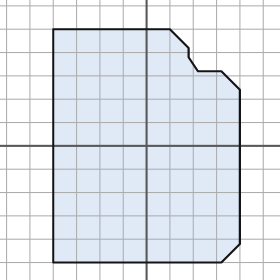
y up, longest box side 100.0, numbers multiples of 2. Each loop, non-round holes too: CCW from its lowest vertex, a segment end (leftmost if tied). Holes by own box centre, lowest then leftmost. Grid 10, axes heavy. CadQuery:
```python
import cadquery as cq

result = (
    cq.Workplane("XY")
    .moveTo(-40.0, -50.0)
    .lineTo(32.0, -50.0)
    .lineTo(40.0, -42.0)
    .lineTo(40.0, 24.0)
    .lineTo(32.0, 32.0)
    .lineTo(22.0, 32.0)
    .lineTo(18.0, 38.0)
    .lineTo(18.0, 42.0)
    .lineTo(10.0, 50.0)
    .lineTo(-40.0, 50.0)
    .close()
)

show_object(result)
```